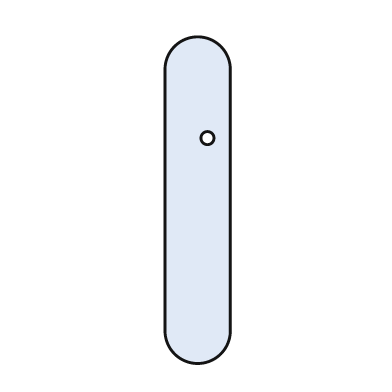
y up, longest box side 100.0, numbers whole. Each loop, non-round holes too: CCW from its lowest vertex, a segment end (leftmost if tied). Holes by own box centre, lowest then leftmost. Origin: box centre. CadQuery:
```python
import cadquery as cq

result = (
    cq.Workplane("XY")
    .moveTo(-10.0, -40.0)
    .threePointArc((0.0, -50.0), (10.0, -40.0))
    .lineTo(10.0, 40.0)
    .threePointArc((0.0, 50.0), (-10.0, 40.0))
    .close()
    .moveTo(3.0, 19.0)
    .circle(2.0)
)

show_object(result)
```